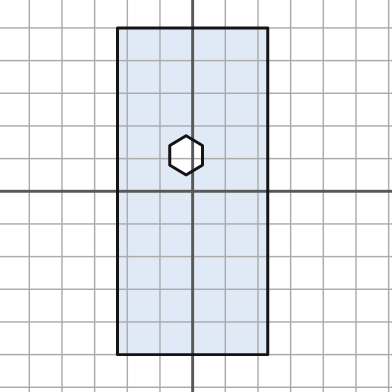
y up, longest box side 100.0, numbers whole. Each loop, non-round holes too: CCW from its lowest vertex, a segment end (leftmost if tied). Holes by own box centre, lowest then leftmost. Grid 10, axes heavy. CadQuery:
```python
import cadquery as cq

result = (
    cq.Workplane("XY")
    .moveTo(-23.0, -50.0)
    .lineTo(23.0, -50.0)
    .lineTo(23.0, 50.0)
    .lineTo(-23.0, 50.0)
    .close()
    .moveTo(-2.0, 5.0)
    .lineTo(3.0, 8.0)
    .lineTo(3.0, 14.0)
    .lineTo(-2.0, 17.0)
    .lineTo(-7.0, 14.0)
    .lineTo(-7.0, 8.0)
    .close()
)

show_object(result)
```